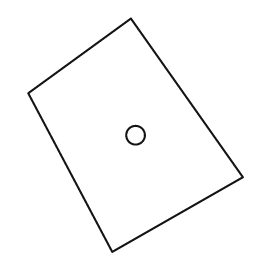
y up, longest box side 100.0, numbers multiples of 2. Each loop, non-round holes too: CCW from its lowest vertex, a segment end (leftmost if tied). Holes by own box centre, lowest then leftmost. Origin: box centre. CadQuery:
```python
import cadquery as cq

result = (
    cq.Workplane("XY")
    .moveTo(-10.0, -50.0)
    .lineTo(46.0, -18.0)
    .lineTo(-2.0, 50.0)
    .lineTo(-46.0, 18.0)
    .close()
    .moveTo(0.0, 0.0)
    .circle(4.0)
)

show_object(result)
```